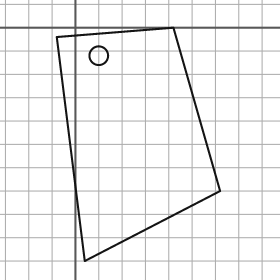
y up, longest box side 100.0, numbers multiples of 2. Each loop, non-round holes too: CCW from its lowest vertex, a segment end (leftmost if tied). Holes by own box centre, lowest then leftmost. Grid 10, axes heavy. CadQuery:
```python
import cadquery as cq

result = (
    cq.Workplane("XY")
    .moveTo(4.0, -100.0)
    .lineTo(62.0, -70.0)
    .lineTo(42.0, 0.0)
    .lineTo(-8.0, -4.0)
    .close()
    .moveTo(10.0, -12.0)
    .circle(4.0)
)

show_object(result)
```